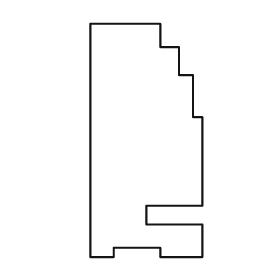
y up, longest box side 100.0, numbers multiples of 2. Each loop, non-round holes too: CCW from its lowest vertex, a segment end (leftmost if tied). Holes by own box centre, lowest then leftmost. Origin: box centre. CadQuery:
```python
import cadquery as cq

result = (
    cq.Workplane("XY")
    .moveTo(-24.0, -50.0)
    .lineTo(-14.0, -50.0)
    .lineTo(-14.0, -46.0)
    .lineTo(6.0, -46.0)
    .lineTo(6.0, -50.0)
    .lineTo(24.0, -50.0)
    .lineTo(24.0, -36.0)
    .lineTo(0.0, -36.0)
    .lineTo(0.0, -28.0)
    .lineTo(24.0, -28.0)
    .lineTo(24.0, 10.0)
    .lineTo(20.0, 10.0)
    .lineTo(20.0, 28.0)
    .lineTo(14.0, 28.0)
    .lineTo(14.0, 40.0)
    .lineTo(6.0, 40.0)
    .lineTo(6.0, 50.0)
    .lineTo(-24.0, 50.0)
    .close()
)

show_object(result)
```